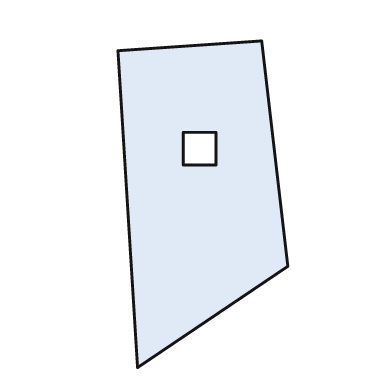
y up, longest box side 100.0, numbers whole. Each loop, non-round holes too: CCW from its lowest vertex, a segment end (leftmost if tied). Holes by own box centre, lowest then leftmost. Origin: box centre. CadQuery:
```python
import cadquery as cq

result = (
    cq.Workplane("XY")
    .moveTo(-20.0, -50.0)
    .lineTo(26.0, -19.0)
    .lineTo(18.0, 50.0)
    .lineTo(-26.0, 47.0)
    .close()
    .moveTo(-6.0, 12.0)
    .lineTo(4.0, 12.0)
    .lineTo(4.0, 22.0)
    .lineTo(-6.0, 22.0)
    .close()
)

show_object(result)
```